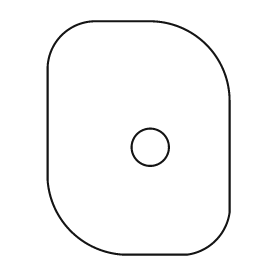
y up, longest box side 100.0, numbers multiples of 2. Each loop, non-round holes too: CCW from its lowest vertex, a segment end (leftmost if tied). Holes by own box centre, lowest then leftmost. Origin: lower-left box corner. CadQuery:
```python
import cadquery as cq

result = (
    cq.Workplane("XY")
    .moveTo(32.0, 0.0)
    .lineTo(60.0, 0.0)
    .threePointArc((72.0, 6.0), (78.0, 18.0))
    .lineTo(78.0, 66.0)
    .threePointArc((68.0, 90.0), (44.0, 100.0))
    .lineTo(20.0, 100.0)
    .threePointArc((6.0, 94.0), (0.0, 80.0))
    .lineTo(0.0, 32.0)
    .threePointArc((10.0, 10.0), (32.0, 0.0))
    .close()
    .moveTo(44.0, 46.0)
    .circle(8.0)
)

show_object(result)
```